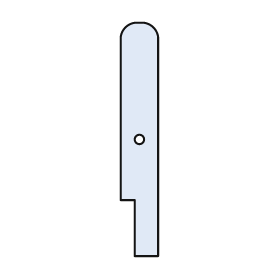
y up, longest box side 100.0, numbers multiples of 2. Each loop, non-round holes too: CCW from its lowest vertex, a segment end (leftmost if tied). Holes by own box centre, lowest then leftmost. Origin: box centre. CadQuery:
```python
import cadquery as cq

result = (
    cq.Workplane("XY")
    .moveTo(-2.0, -50.0)
    .lineTo(8.0, -50.0)
    .lineTo(8.0, 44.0)
    .threePointArc((6.0, 48.0), (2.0, 50.0))
    .lineTo(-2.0, 50.0)
    .threePointArc((-6.0, 48.0), (-8.0, 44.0))
    .lineTo(-8.0, -26.0)
    .lineTo(-2.0, -26.0)
    .close()
    .moveTo(0.0, 0.0)
    .circle(2.0)
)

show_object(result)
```